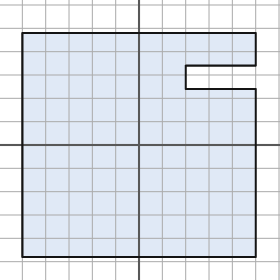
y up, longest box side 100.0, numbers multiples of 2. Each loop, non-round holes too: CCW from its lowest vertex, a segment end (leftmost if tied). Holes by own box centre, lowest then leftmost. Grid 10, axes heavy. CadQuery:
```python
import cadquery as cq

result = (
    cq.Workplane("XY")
    .moveTo(-50.0, -48.0)
    .lineTo(50.0, -48.0)
    .lineTo(50.0, 24.0)
    .lineTo(20.0, 24.0)
    .lineTo(20.0, 34.0)
    .lineTo(50.0, 34.0)
    .lineTo(50.0, 48.0)
    .lineTo(-50.0, 48.0)
    .close()
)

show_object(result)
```